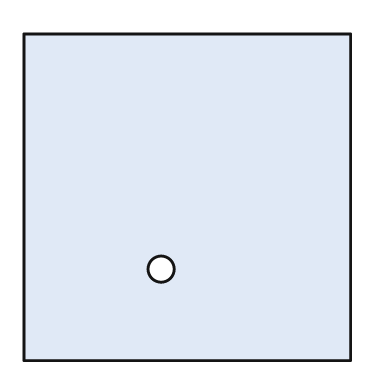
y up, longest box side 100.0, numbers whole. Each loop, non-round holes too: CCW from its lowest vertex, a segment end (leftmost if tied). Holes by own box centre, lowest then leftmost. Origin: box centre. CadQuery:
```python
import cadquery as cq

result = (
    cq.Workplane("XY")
    .moveTo(-50.0, -50.0)
    .lineTo(50.0, -50.0)
    .lineTo(50.0, 50.0)
    .lineTo(-50.0, 50.0)
    .close()
    .moveTo(-8.0, -22.0)
    .circle(4.0)
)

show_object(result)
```